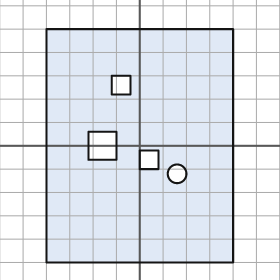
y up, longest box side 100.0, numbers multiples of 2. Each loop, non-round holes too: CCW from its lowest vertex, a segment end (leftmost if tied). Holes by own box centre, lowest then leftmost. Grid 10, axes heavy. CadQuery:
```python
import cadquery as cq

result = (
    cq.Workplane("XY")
    .moveTo(-40.0, -50.0)
    .lineTo(40.0, -50.0)
    .lineTo(40.0, 50.0)
    .lineTo(-40.0, 50.0)
    .close()
    .moveTo(16.0, -12.0)
    .circle(4.0)
    .moveTo(0.0, -10.0)
    .lineTo(8.0, -10.0)
    .lineTo(8.0, -2.0)
    .lineTo(0.0, -2.0)
    .close()
    .moveTo(-22.0, -6.0)
    .lineTo(-10.0, -6.0)
    .lineTo(-10.0, 6.0)
    .lineTo(-22.0, 6.0)
    .close()
    .moveTo(-12.0, 22.0)
    .lineTo(-4.0, 22.0)
    .lineTo(-4.0, 30.0)
    .lineTo(-12.0, 30.0)
    .close()
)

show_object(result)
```